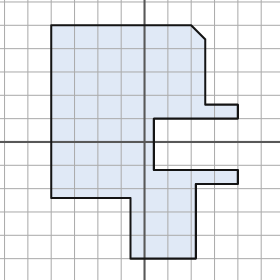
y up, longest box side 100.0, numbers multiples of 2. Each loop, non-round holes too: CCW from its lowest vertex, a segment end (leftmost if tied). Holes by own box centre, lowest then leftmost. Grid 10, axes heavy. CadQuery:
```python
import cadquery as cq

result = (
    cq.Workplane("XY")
    .moveTo(-6.0, -50.0)
    .lineTo(22.0, -50.0)
    .lineTo(22.0, -18.0)
    .lineTo(40.0, -18.0)
    .lineTo(40.0, -12.0)
    .lineTo(4.0, -12.0)
    .lineTo(4.0, 10.0)
    .lineTo(40.0, 10.0)
    .lineTo(40.0, 16.0)
    .lineTo(26.0, 16.0)
    .lineTo(26.0, 44.0)
    .lineTo(20.0, 50.0)
    .lineTo(-40.0, 50.0)
    .lineTo(-40.0, -24.0)
    .lineTo(-6.0, -24.0)
    .close()
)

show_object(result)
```